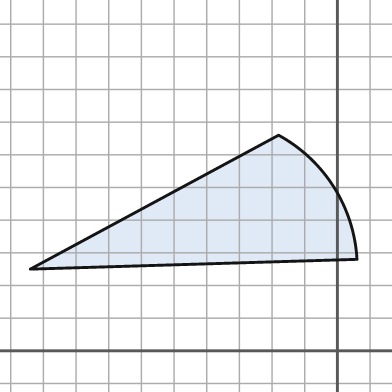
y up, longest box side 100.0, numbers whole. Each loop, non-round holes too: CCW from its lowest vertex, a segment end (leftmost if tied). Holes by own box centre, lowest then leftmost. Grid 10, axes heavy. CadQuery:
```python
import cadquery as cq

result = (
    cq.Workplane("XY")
    .moveTo(-94.0, 25.0)
    .lineTo(6.0, 28.0)
    .threePointArc((-1.0, 50.0), (-18.0, 66.0))
    .close()
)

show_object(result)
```